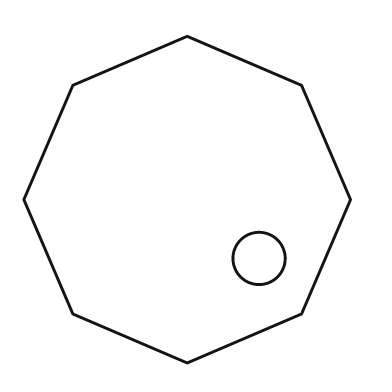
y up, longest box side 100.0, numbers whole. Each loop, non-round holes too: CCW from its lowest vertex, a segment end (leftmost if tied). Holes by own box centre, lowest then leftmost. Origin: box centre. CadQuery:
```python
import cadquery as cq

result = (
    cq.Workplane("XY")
    .moveTo(0.0, -50.0)
    .lineTo(35.0, -35.0)
    .lineTo(50.0, 0.0)
    .lineTo(35.0, 35.0)
    .lineTo(0.0, 50.0)
    .lineTo(-35.0, 35.0)
    .lineTo(-50.0, 0.0)
    .lineTo(-35.0, -35.0)
    .close()
    .moveTo(22.0, -18.0)
    .circle(8.0)
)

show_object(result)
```